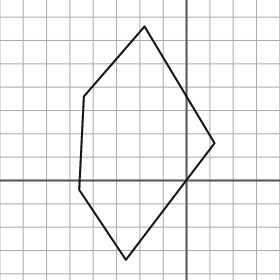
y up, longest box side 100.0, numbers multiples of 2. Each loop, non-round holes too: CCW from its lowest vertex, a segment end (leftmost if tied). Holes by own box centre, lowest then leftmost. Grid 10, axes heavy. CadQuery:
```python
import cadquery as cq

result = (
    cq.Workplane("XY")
    .moveTo(-26.0, -34.0)
    .lineTo(12.0, 16.0)
    .lineTo(-18.0, 66.0)
    .lineTo(-44.0, 36.0)
    .lineTo(-46.0, -4.0)
    .close()
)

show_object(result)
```